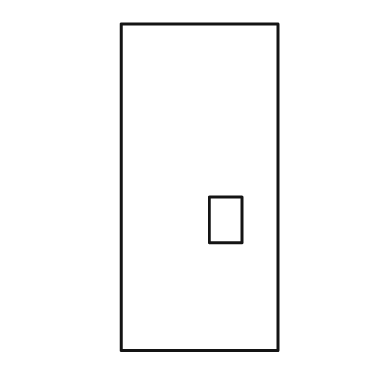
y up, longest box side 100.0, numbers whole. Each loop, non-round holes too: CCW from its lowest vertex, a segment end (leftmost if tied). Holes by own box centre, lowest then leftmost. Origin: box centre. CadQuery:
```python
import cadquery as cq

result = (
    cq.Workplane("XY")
    .moveTo(-24.0, -50.0)
    .lineTo(24.0, -50.0)
    .lineTo(24.0, 50.0)
    .lineTo(-24.0, 50.0)
    .close()
    .moveTo(3.0, -17.0)
    .lineTo(13.0, -17.0)
    .lineTo(13.0, -3.0)
    .lineTo(3.0, -3.0)
    .close()
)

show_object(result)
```